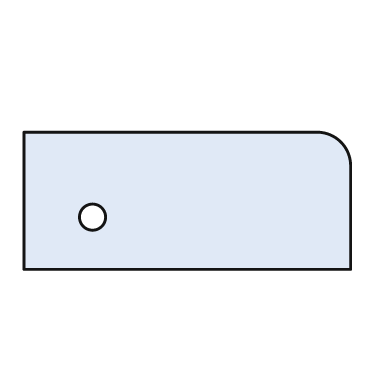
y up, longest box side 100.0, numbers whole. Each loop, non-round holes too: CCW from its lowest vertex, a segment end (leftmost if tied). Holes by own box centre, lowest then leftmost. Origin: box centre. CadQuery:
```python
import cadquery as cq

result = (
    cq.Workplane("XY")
    .moveTo(-50.0, -21.0)
    .lineTo(50.0, -21.0)
    .lineTo(50.0, 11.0)
    .threePointArc((47.0, 18.0), (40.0, 21.0))
    .lineTo(-50.0, 21.0)
    .close()
    .moveTo(-29.0, -5.0)
    .circle(4.0)
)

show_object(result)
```